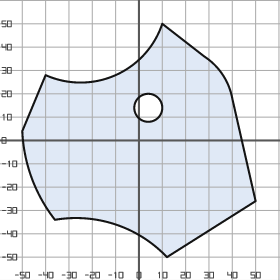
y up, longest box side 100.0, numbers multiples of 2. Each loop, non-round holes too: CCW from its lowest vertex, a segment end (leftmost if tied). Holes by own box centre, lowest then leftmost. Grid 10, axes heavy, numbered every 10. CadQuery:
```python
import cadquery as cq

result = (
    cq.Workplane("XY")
    .moveTo(12.0, -50.0)
    .lineTo(50.0, -26.0)
    .lineTo(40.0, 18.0)
    .threePointArc((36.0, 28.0), (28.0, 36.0))
    .lineTo(10.0, 50.0)
    .threePointArc((-10.0, 28.0), (-40.0, 28.0))
    .lineTo(-50.0, 4.0)
    .threePointArc((-46.0, -16.0), (-36.0, -34.0))
    .threePointArc((-10.0, -36.0), (12.0, -50.0))
    .close()
    .moveTo(4.0, 14.0)
    .circle(6.0)
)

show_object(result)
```